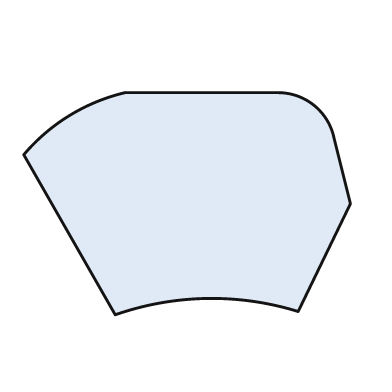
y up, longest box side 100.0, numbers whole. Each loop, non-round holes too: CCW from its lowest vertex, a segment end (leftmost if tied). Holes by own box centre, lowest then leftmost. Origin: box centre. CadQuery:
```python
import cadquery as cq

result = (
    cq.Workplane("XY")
    .moveTo(-22.0, -34.0)
    .threePointArc((6.0, -29.0), (34.0, -33.0))
    .lineTo(50.0, 0.0)
    .lineTo(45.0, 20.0)
    .threePointArc((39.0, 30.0), (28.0, 34.0))
    .lineTo(-19.0, 34.0)
    .threePointArc((-36.0, 27.0), (-50.0, 15.0))
    .close()
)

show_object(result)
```